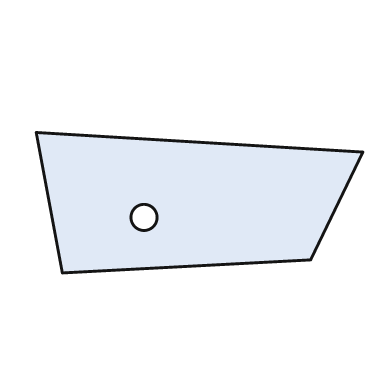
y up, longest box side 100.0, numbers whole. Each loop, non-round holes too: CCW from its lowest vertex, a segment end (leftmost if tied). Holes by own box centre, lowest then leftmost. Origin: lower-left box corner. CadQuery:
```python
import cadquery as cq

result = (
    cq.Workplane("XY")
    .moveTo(8.0, 0.0)
    .lineTo(84.0, 4.0)
    .lineTo(100.0, 37.0)
    .lineTo(0.0, 43.0)
    .close()
    .moveTo(33.0, 17.0)
    .circle(4.0)
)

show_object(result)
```